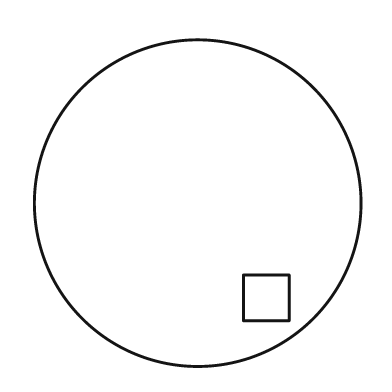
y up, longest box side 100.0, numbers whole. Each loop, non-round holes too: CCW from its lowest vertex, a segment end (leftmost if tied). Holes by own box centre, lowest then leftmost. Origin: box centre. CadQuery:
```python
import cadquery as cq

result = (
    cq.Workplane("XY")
    .moveTo(0.0, 0.0)
    .circle(50.0)
    .moveTo(14.0, -36.0)
    .lineTo(28.0, -36.0)
    .lineTo(28.0, -22.0)
    .lineTo(14.0, -22.0)
    .close()
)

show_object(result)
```